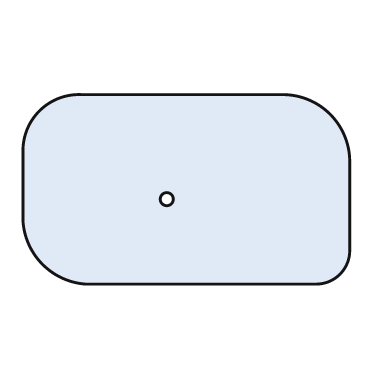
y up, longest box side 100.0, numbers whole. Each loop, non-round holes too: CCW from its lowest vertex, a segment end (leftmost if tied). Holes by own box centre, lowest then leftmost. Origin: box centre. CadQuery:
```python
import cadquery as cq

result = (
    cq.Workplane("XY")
    .moveTo(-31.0, -29.0)
    .lineTo(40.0, -29.0)
    .threePointArc((47.0, -26.0), (50.0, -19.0))
    .lineTo(50.0, 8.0)
    .threePointArc((44.0, 23.0), (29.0, 29.0))
    .lineTo(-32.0, 29.0)
    .threePointArc((-45.0, 24.0), (-50.0, 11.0))
    .lineTo(-50.0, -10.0)
    .threePointArc((-44.0, -23.0), (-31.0, -29.0))
    .close()
    .moveTo(-6.0, -3.0)
    .circle(2.0)
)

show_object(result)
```